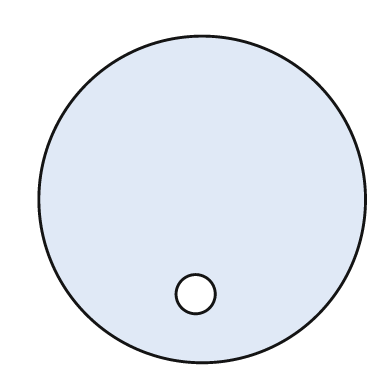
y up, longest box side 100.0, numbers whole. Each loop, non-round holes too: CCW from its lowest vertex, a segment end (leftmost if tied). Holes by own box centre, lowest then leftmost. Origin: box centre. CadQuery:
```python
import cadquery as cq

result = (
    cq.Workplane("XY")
    .moveTo(0.0, 0.0)
    .circle(50.0)
    .moveTo(-2.0, -29.0)
    .circle(6.0)
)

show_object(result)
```